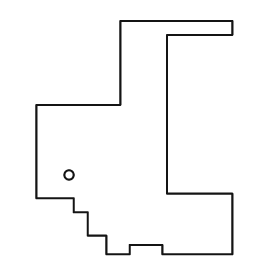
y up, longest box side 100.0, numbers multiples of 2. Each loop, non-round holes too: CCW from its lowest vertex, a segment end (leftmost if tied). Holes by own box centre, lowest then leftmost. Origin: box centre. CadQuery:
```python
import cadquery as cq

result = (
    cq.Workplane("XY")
    .moveTo(-12.0, -50.0)
    .lineTo(-2.0, -50.0)
    .lineTo(-2.0, -46.0)
    .lineTo(12.0, -46.0)
    .lineTo(12.0, -50.0)
    .lineTo(42.0, -50.0)
    .lineTo(42.0, -24.0)
    .lineTo(14.0, -24.0)
    .lineTo(14.0, 44.0)
    .lineTo(42.0, 44.0)
    .lineTo(42.0, 50.0)
    .lineTo(-6.0, 50.0)
    .lineTo(-6.0, 14.0)
    .lineTo(-42.0, 14.0)
    .lineTo(-42.0, -26.0)
    .lineTo(-26.0, -26.0)
    .lineTo(-26.0, -32.0)
    .lineTo(-20.0, -32.0)
    .lineTo(-20.0, -42.0)
    .lineTo(-12.0, -42.0)
    .close()
    .moveTo(-28.0, -16.0)
    .circle(2.0)
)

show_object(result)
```